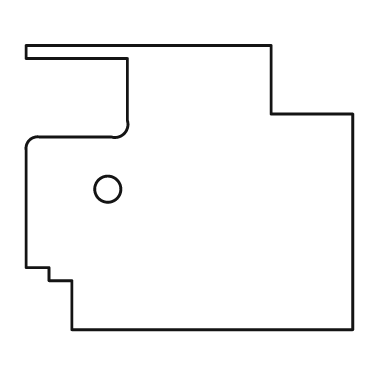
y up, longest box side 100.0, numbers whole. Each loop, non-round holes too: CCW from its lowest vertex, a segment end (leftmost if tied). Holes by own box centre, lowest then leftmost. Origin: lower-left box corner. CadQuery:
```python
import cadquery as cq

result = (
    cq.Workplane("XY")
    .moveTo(14.0, 0.0)
    .lineTo(100.0, 0.0)
    .lineTo(100.0, 66.0)
    .lineTo(75.0, 66.0)
    .lineTo(75.0, 87.0)
    .lineTo(0.0, 87.0)
    .lineTo(0.0, 83.0)
    .lineTo(31.0, 83.0)
    .lineTo(31.0, 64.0)
    .threePointArc((30.0, 60.0), (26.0, 59.0))
    .lineTo(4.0, 59.0)
    .threePointArc((1.0, 58.0), (0.0, 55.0))
    .lineTo(0.0, 19.0)
    .lineTo(7.0, 19.0)
    .lineTo(7.0, 15.0)
    .lineTo(14.0, 15.0)
    .close()
    .moveTo(25.0, 43.0)
    .circle(4.0)
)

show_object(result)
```